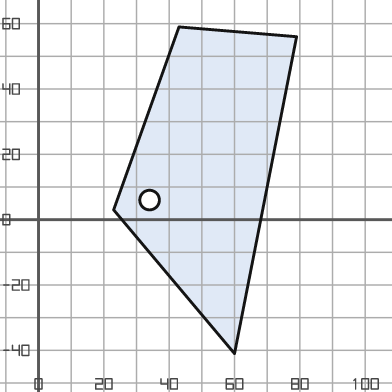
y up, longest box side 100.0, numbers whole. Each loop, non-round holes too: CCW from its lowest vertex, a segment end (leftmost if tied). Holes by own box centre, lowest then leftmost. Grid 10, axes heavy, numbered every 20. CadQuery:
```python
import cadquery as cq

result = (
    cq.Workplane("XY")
    .moveTo(60.0, -41.0)
    .lineTo(79.0, 56.0)
    .lineTo(43.0, 59.0)
    .lineTo(23.0, 3.0)
    .close()
    .moveTo(34.0, 6.0)
    .circle(3.0)
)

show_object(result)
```